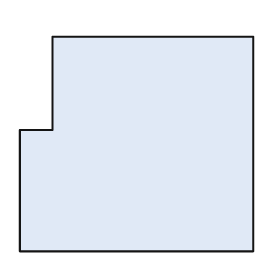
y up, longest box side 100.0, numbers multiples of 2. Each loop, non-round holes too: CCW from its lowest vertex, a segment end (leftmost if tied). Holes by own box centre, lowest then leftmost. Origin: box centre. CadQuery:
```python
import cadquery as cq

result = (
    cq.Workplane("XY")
    .moveTo(-50.0, -46.0)
    .lineTo(50.0, -46.0)
    .lineTo(50.0, 46.0)
    .lineTo(-36.0, 46.0)
    .lineTo(-36.0, 6.0)
    .lineTo(-50.0, 6.0)
    .close()
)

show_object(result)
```